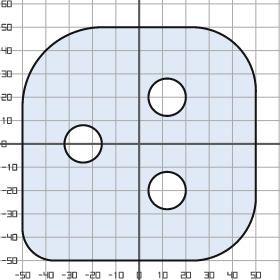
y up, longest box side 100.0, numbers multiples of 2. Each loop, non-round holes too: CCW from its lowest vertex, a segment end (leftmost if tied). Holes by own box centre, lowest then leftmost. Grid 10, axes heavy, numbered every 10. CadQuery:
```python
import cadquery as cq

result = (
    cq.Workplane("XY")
    .moveTo(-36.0, -50.0)
    .lineTo(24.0, -50.0)
    .threePointArc((42.0, -42.0), (50.0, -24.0))
    .lineTo(50.0, 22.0)
    .threePointArc((42.0, 42.0), (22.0, 50.0))
    .lineTo(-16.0, 50.0)
    .threePointArc((-40.0, 40.0), (-50.0, 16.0))
    .lineTo(-50.0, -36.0)
    .threePointArc((-46.0, -46.0), (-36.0, -50.0))
    .close()
    .moveTo(12.0, -20.0)
    .circle(8.0)
    .moveTo(-24.0, 0.0)
    .circle(8.0)
    .moveTo(12.0, 20.0)
    .circle(8.0)
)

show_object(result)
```